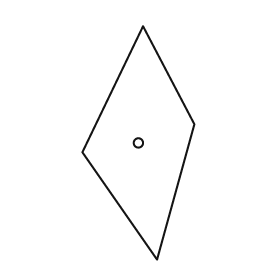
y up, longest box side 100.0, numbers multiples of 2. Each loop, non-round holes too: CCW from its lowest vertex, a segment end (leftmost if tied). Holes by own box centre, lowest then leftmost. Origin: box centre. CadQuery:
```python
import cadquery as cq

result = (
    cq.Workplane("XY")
    .moveTo(8.0, -50.0)
    .lineTo(24.0, 8.0)
    .lineTo(2.0, 50.0)
    .lineTo(-24.0, -4.0)
    .close()
    .moveTo(0.0, 0.0)
    .circle(2.0)
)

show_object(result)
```